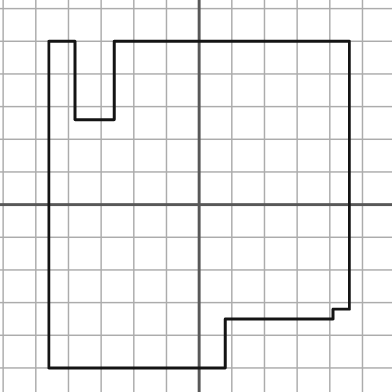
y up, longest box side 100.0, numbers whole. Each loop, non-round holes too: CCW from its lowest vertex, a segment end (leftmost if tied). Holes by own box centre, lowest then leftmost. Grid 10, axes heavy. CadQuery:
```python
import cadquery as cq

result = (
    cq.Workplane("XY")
    .moveTo(-46.0, -50.0)
    .lineTo(8.0, -50.0)
    .lineTo(8.0, -35.0)
    .lineTo(41.0, -35.0)
    .lineTo(41.0, -32.0)
    .lineTo(46.0, -32.0)
    .lineTo(46.0, 50.0)
    .lineTo(-26.0, 50.0)
    .lineTo(-26.0, 26.0)
    .lineTo(-38.0, 26.0)
    .lineTo(-38.0, 50.0)
    .lineTo(-46.0, 50.0)
    .close()
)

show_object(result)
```